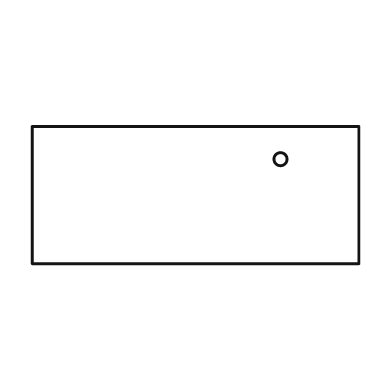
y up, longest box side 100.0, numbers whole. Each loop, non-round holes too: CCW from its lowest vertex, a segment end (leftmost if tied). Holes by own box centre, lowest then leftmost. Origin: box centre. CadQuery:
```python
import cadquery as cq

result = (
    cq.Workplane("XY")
    .moveTo(-50.0, -21.0)
    .lineTo(50.0, -21.0)
    .lineTo(50.0, 21.0)
    .lineTo(-50.0, 21.0)
    .close()
    .moveTo(26.0, 11.0)
    .circle(2.0)
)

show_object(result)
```